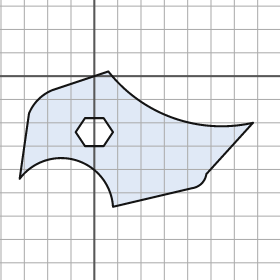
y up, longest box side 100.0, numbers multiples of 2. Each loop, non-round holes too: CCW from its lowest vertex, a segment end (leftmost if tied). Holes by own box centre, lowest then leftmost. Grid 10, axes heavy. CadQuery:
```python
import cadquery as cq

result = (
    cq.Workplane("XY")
    .moveTo(8.0, -56.0)
    .lineTo(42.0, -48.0)
    .threePointArc((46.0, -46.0), (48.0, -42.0))
    .lineTo(68.0, -20.0)
    .threePointArc((34.0, -18.0), (6.0, 2.0))
    .lineTo(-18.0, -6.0)
    .threePointArc((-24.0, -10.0), (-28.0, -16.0))
    .lineTo(-32.0, -44.0)
    .threePointArc((-8.0, -36.0), (8.0, -56.0))
    .close()
    .moveTo(-4.0, -30.0)
    .lineTo(4.0, -30.0)
    .lineTo(8.0, -24.0)
    .lineTo(4.0, -18.0)
    .lineTo(-4.0, -18.0)
    .lineTo(-8.0, -24.0)
    .close()
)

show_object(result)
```